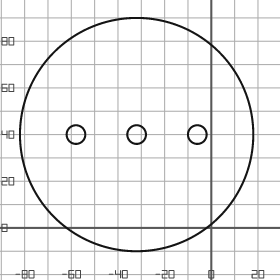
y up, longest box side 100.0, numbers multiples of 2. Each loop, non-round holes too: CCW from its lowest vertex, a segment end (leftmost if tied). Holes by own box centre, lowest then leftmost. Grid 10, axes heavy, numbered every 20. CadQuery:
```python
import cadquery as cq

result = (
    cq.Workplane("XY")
    .moveTo(-32.0, 40.0)
    .circle(50.0)
    .moveTo(-58.0, 40.0)
    .circle(4.0)
    .moveTo(-32.0, 40.0)
    .circle(4.0)
    .moveTo(-6.0, 40.0)
    .circle(4.0)
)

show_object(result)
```